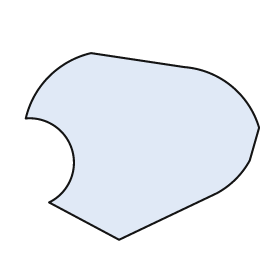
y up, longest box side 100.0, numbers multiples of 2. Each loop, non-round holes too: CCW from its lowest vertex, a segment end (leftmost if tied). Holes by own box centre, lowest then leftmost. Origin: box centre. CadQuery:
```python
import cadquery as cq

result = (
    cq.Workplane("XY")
    .moveTo(-10.0, -40.0)
    .lineTo(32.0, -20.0)
    .threePointArc((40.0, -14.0), (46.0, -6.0))
    .lineTo(50.0, 8.0)
    .threePointArc((38.0, 26.0), (18.0, 34.0))
    .lineTo(-22.0, 40.0)
    .threePointArc((-40.0, 30.0), (-50.0, 12.0))
    .threePointArc((-30.0, -2.0), (-40.0, -24.0))
    .close()
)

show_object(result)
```